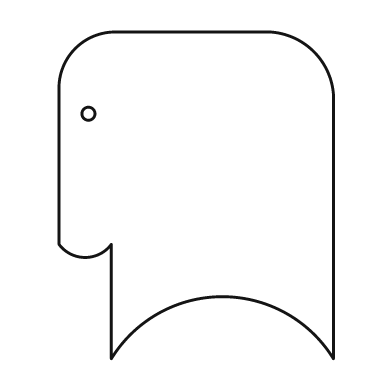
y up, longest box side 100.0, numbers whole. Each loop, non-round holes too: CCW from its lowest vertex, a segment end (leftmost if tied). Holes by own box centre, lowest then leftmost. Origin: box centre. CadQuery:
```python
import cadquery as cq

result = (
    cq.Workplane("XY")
    .moveTo(-26.0, -50.0)
    .threePointArc((8.0, -31.0), (42.0, -50.0))
    .lineTo(42.0, 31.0)
    .threePointArc((36.0, 44.0), (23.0, 50.0))
    .lineTo(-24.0, 50.0)
    .threePointArc((-37.0, 45.0), (-42.0, 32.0))
    .lineTo(-42.0, -15.0)
    .threePointArc((-34.0, -19.0), (-26.0, -15.0))
    .close()
    .moveTo(-33.0, 25.0)
    .circle(2.0)
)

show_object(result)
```